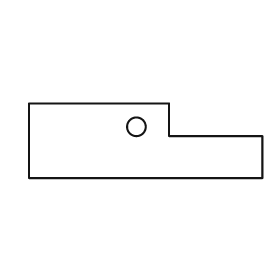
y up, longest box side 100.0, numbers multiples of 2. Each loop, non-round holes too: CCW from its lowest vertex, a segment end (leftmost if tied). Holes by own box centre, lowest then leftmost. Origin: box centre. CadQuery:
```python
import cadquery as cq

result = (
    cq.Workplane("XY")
    .moveTo(-50.0, -16.0)
    .lineTo(50.0, -16.0)
    .lineTo(50.0, 2.0)
    .lineTo(10.0, 2.0)
    .lineTo(10.0, 16.0)
    .lineTo(-50.0, 16.0)
    .close()
    .moveTo(-4.0, 6.0)
    .circle(4.0)
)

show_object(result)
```